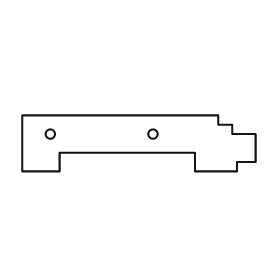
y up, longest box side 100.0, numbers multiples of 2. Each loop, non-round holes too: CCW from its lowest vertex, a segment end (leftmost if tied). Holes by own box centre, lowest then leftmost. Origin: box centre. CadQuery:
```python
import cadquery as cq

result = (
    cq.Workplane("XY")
    .moveTo(-50.0, -12.0)
    .lineTo(-34.0, -12.0)
    .lineTo(-34.0, -4.0)
    .lineTo(24.0, -4.0)
    .lineTo(24.0, -12.0)
    .lineTo(42.0, -12.0)
    .lineTo(42.0, -8.0)
    .lineTo(50.0, -8.0)
    .lineTo(50.0, 4.0)
    .lineTo(40.0, 4.0)
    .lineTo(40.0, 8.0)
    .lineTo(34.0, 8.0)
    .lineTo(34.0, 12.0)
    .lineTo(-50.0, 12.0)
    .close()
    .moveTo(-38.0, 4.0)
    .circle(2.0)
    .moveTo(6.0, 4.0)
    .circle(2.0)
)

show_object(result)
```